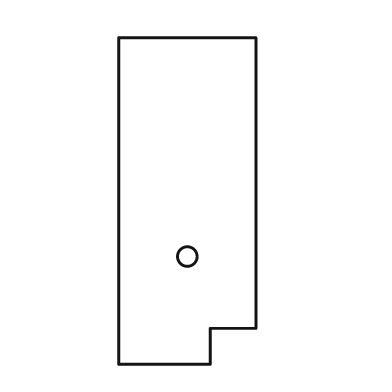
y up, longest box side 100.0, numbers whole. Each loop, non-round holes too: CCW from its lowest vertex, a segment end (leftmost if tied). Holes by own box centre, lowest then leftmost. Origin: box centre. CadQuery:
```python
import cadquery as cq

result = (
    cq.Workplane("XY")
    .moveTo(-21.0, -50.0)
    .lineTo(7.0, -50.0)
    .lineTo(7.0, -39.0)
    .lineTo(21.0, -39.0)
    .lineTo(21.0, 50.0)
    .lineTo(-21.0, 50.0)
    .close()
    .moveTo(0.0, -17.0)
    .circle(3.0)
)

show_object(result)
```